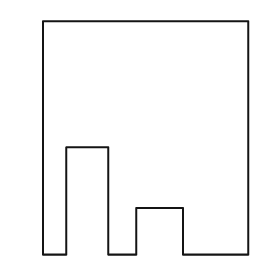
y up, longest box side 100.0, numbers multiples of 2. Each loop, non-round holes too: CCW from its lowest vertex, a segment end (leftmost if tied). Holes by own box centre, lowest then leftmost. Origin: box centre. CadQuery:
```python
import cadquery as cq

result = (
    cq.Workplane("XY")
    .moveTo(-44.0, -50.0)
    .lineTo(-34.0, -50.0)
    .lineTo(-34.0, -4.0)
    .lineTo(-16.0, -4.0)
    .lineTo(-16.0, -50.0)
    .lineTo(-4.0, -50.0)
    .lineTo(-4.0, -30.0)
    .lineTo(16.0, -30.0)
    .lineTo(16.0, -50.0)
    .lineTo(44.0, -50.0)
    .lineTo(44.0, 50.0)
    .lineTo(-44.0, 50.0)
    .close()
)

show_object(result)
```